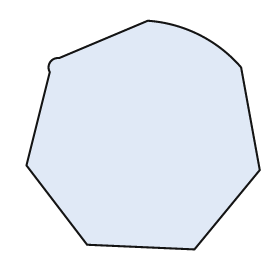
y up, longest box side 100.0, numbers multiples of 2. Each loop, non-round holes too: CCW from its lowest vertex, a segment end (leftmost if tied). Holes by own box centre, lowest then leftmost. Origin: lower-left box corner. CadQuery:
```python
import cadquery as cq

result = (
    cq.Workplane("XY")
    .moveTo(72.0, 0.0)
    .lineTo(100.0, 34.0)
    .lineTo(92.0, 78.0)
    .threePointArc((74.0, 92.0), (52.0, 98.0))
    .lineTo(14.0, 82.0)
    .threePointArc((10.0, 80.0), (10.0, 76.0))
    .lineTo(0.0, 36.0)
    .lineTo(26.0, 2.0)
    .close()
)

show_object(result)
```